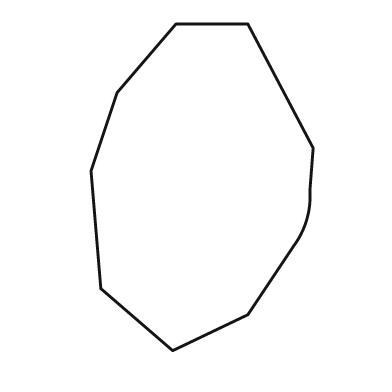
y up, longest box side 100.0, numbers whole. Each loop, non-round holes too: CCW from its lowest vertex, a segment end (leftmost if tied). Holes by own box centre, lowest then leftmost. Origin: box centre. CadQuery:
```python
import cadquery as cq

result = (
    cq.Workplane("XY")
    .moveTo(-9.0, -50.0)
    .lineTo(14.0, -39.0)
    .lineTo(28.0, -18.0)
    .threePointArc((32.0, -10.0), (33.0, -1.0))
    .lineTo(34.0, 12.0)
    .lineTo(14.0, 50.0)
    .lineTo(-8.0, 50.0)
    .lineTo(-26.0, 29.0)
    .lineTo(-34.0, 5.0)
    .lineTo(-31.0, -31.0)
    .close()
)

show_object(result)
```